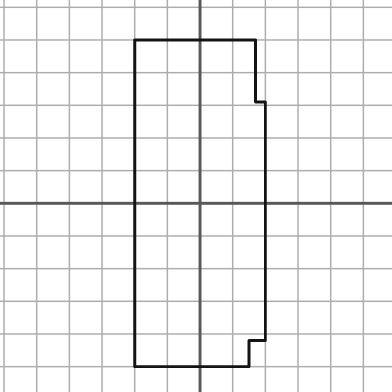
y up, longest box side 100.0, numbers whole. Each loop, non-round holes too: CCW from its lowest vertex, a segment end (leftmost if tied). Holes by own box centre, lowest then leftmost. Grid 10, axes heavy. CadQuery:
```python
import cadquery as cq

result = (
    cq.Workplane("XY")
    .moveTo(-20.0, -50.0)
    .lineTo(15.0, -50.0)
    .lineTo(15.0, -42.0)
    .lineTo(20.0, -42.0)
    .lineTo(20.0, 31.0)
    .lineTo(17.0, 31.0)
    .lineTo(17.0, 50.0)
    .lineTo(-20.0, 50.0)
    .close()
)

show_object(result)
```